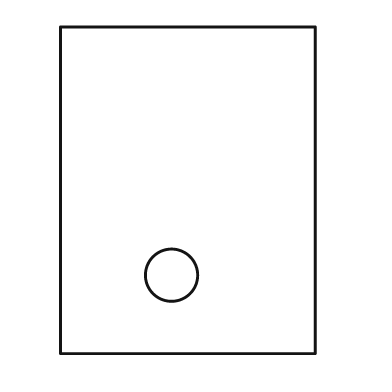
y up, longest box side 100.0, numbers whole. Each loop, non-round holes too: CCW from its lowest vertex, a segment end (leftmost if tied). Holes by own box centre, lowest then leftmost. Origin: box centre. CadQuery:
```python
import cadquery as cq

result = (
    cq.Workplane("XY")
    .moveTo(-39.0, -50.0)
    .lineTo(39.0, -50.0)
    .lineTo(39.0, 50.0)
    .lineTo(-39.0, 50.0)
    .close()
    .moveTo(-5.0, -26.0)
    .circle(8.0)
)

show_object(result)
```